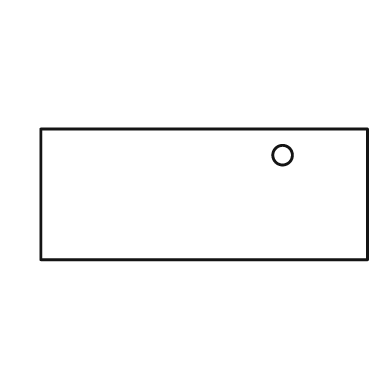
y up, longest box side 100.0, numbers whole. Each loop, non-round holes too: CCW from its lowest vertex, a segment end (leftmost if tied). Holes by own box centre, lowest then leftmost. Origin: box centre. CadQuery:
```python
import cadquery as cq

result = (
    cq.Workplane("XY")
    .moveTo(-50.0, -20.0)
    .lineTo(50.0, -20.0)
    .lineTo(50.0, 20.0)
    .lineTo(-50.0, 20.0)
    .close()
    .moveTo(24.0, 12.0)
    .circle(3.0)
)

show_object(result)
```